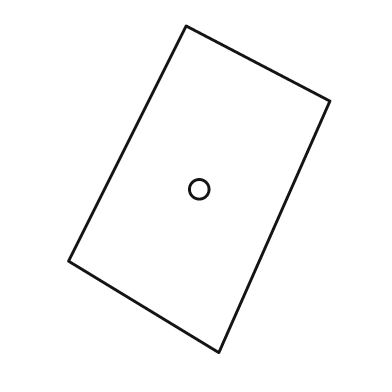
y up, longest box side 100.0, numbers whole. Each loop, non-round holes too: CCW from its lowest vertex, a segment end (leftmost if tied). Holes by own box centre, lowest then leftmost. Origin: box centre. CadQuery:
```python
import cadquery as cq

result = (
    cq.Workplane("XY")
    .moveTo(6.0, -50.0)
    .lineTo(40.0, 27.0)
    .lineTo(-4.0, 50.0)
    .lineTo(-40.0, -22.0)
    .close()
    .moveTo(0.0, 0.0)
    .circle(3.0)
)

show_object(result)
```